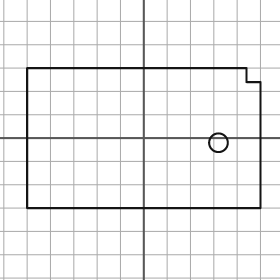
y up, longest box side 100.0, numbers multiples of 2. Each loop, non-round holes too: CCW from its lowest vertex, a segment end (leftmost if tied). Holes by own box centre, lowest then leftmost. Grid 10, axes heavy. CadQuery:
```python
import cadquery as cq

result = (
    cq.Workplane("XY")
    .moveTo(-50.0, -30.0)
    .lineTo(50.0, -30.0)
    .lineTo(50.0, 24.0)
    .lineTo(44.0, 24.0)
    .lineTo(44.0, 30.0)
    .lineTo(-50.0, 30.0)
    .close()
    .moveTo(32.0, -2.0)
    .circle(4.0)
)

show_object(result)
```